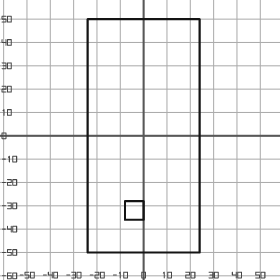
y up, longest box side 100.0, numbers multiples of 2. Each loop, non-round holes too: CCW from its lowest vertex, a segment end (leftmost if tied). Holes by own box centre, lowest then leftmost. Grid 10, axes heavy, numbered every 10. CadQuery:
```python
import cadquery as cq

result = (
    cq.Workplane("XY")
    .moveTo(-24.0, -50.0)
    .lineTo(24.0, -50.0)
    .lineTo(24.0, 50.0)
    .lineTo(-24.0, 50.0)
    .close()
    .moveTo(-8.0, -36.0)
    .lineTo(0.0, -36.0)
    .lineTo(0.0, -28.0)
    .lineTo(-8.0, -28.0)
    .close()
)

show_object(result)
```